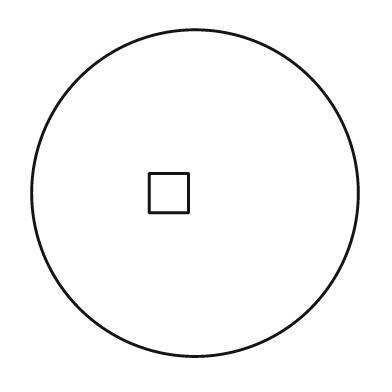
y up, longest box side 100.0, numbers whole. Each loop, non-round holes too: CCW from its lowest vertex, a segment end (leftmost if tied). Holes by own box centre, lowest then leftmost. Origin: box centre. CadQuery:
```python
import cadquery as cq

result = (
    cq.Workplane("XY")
    .moveTo(0.0, 0.0)
    .circle(50.0)
    .moveTo(-14.0, -6.0)
    .lineTo(-2.0, -6.0)
    .lineTo(-2.0, 6.0)
    .lineTo(-14.0, 6.0)
    .close()
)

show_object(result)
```